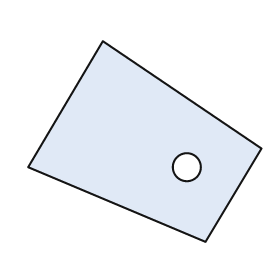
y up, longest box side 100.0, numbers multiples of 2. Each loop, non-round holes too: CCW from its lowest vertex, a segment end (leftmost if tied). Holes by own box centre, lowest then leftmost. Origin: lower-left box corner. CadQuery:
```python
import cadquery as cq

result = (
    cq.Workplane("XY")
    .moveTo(76.0, 0.0)
    .lineTo(100.0, 40.0)
    .lineTo(32.0, 86.0)
    .lineTo(0.0, 32.0)
    .close()
    .moveTo(68.0, 32.0)
    .circle(6.0)
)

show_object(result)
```